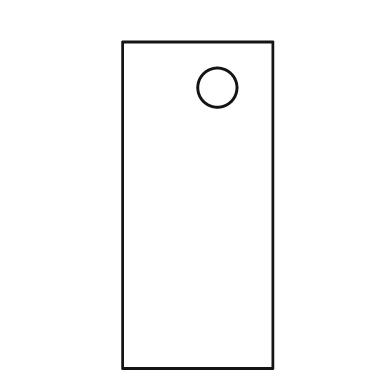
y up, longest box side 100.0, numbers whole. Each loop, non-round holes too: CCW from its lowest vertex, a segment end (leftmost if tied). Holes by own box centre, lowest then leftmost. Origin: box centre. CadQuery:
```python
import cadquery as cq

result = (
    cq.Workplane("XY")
    .moveTo(-23.0, -50.0)
    .lineTo(23.0, -50.0)
    .lineTo(23.0, 50.0)
    .lineTo(-23.0, 50.0)
    .close()
    .moveTo(6.0, 36.0)
    .circle(6.0)
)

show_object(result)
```